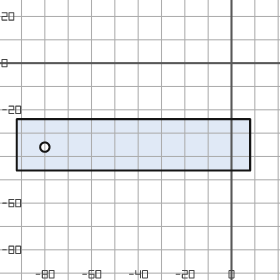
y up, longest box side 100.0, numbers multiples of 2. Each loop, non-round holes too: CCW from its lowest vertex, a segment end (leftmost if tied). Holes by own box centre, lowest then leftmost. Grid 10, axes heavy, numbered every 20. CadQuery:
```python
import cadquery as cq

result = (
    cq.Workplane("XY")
    .moveTo(-92.0, -46.0)
    .lineTo(8.0, -46.0)
    .lineTo(8.0, -24.0)
    .lineTo(-92.0, -24.0)
    .close()
    .moveTo(-80.0, -36.0)
    .circle(2.0)
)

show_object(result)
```